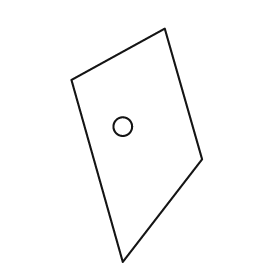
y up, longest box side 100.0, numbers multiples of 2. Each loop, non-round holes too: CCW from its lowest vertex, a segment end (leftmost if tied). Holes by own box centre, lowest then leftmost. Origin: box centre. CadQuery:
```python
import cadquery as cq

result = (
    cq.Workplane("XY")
    .moveTo(-6.0, -50.0)
    .lineTo(28.0, -6.0)
    .lineTo(12.0, 50.0)
    .lineTo(-28.0, 28.0)
    .close()
    .moveTo(-6.0, 8.0)
    .circle(4.0)
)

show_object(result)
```